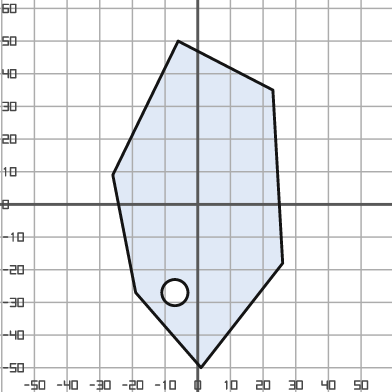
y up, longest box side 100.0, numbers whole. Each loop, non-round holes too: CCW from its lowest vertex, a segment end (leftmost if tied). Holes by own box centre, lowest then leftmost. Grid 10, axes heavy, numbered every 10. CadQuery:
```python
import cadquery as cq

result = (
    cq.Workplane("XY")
    .moveTo(1.0, -50.0)
    .lineTo(26.0, -18.0)
    .lineTo(23.0, 35.0)
    .lineTo(-6.0, 50.0)
    .lineTo(-26.0, 9.0)
    .lineTo(-19.0, -27.0)
    .close()
    .moveTo(-7.0, -27.0)
    .circle(4.0)
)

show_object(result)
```